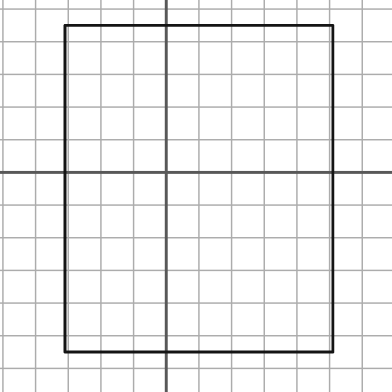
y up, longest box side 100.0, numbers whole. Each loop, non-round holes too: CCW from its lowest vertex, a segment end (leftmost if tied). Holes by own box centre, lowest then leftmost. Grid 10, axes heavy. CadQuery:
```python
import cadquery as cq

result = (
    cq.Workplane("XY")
    .moveTo(-31.0, -55.0)
    .lineTo(51.0, -55.0)
    .lineTo(51.0, 45.0)
    .lineTo(-31.0, 45.0)
    .close()
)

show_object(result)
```